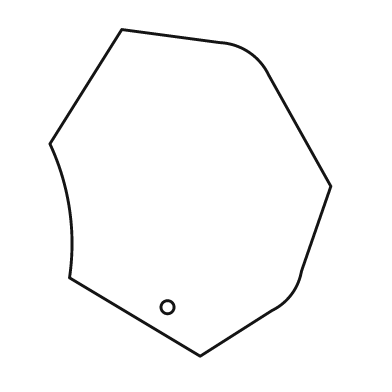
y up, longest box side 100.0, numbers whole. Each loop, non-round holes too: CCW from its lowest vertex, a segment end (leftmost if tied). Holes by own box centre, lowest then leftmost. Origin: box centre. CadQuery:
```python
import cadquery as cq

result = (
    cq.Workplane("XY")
    .moveTo(3.0, -50.0)
    .lineTo(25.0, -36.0)
    .threePointArc((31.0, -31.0), (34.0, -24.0))
    .lineTo(43.0, 2.0)
    .lineTo(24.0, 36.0)
    .threePointArc((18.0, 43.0), (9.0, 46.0))
    .lineTo(-21.0, 50.0)
    .lineTo(-43.0, 15.0)
    .threePointArc((-37.0, -5.0), (-37.0, -26.0))
    .close()
    .moveTo(-7.0, -35.0)
    .circle(2.0)
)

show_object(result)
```